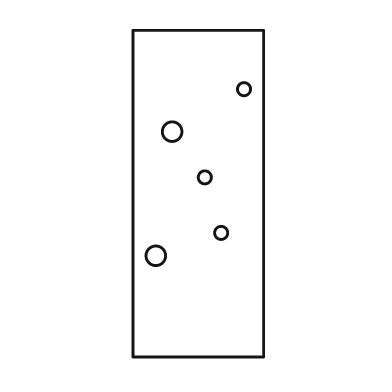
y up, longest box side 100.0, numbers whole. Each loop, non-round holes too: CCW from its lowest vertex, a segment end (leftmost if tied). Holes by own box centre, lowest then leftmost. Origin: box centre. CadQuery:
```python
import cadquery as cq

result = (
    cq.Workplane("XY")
    .moveTo(-20.0, -50.0)
    .lineTo(20.0, -50.0)
    .lineTo(20.0, 50.0)
    .lineTo(-20.0, 50.0)
    .close()
    .moveTo(-13.0, -19.0)
    .circle(3.0)
    .moveTo(7.0, -12.0)
    .circle(2.0)
    .moveTo(2.0, 5.0)
    .circle(2.0)
    .moveTo(-8.0, 19.0)
    .circle(3.0)
    .moveTo(14.0, 32.0)
    .circle(2.0)
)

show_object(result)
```